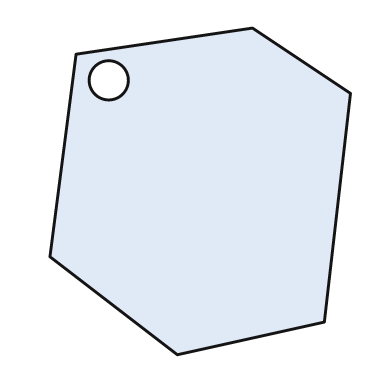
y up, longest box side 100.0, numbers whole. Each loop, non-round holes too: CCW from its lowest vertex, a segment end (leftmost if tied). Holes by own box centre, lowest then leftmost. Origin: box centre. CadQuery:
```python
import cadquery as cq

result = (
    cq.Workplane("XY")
    .moveTo(-7.0, -50.0)
    .lineTo(38.0, -40.0)
    .lineTo(46.0, 30.0)
    .lineTo(16.0, 50.0)
    .lineTo(-38.0, 42.0)
    .lineTo(-46.0, -20.0)
    .close()
    .moveTo(-28.0, 34.0)
    .circle(6.0)
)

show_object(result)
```